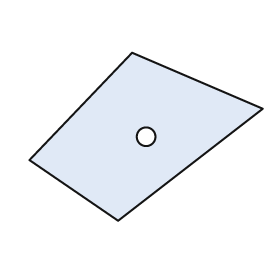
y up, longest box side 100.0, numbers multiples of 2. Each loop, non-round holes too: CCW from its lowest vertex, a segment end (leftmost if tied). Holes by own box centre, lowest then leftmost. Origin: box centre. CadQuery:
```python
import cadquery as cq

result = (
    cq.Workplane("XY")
    .moveTo(-12.0, -36.0)
    .lineTo(50.0, 12.0)
    .lineTo(-6.0, 36.0)
    .lineTo(-50.0, -10.0)
    .close()
    .moveTo(0.0, 0.0)
    .circle(4.0)
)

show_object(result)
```